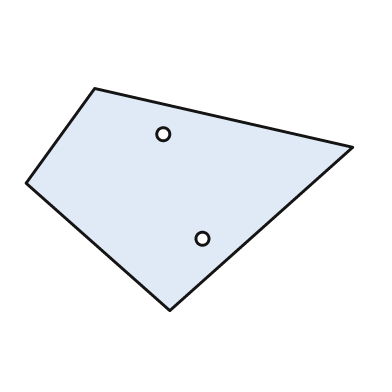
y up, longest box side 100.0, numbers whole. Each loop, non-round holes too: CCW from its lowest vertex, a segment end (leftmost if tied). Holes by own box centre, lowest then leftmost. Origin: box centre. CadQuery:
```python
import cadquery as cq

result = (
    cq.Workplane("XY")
    .moveTo(-6.0, -34.0)
    .lineTo(50.0, 16.0)
    .lineTo(-29.0, 34.0)
    .lineTo(-50.0, 5.0)
    .close()
    .moveTo(4.0, -12.0)
    .circle(2.0)
    .moveTo(-8.0, 20.0)
    .circle(2.0)
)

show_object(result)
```